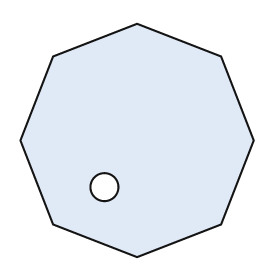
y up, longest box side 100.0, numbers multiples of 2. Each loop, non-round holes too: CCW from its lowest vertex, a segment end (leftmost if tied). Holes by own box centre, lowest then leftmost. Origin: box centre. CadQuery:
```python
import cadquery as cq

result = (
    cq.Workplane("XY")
    .moveTo(0.0, -50.0)
    .lineTo(36.0, -36.0)
    .lineTo(50.0, 0.0)
    .lineTo(36.0, 36.0)
    .lineTo(0.0, 50.0)
    .lineTo(-36.0, 36.0)
    .lineTo(-50.0, 0.0)
    .lineTo(-36.0, -36.0)
    .close()
    .moveTo(-14.0, -20.0)
    .circle(6.0)
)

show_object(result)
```